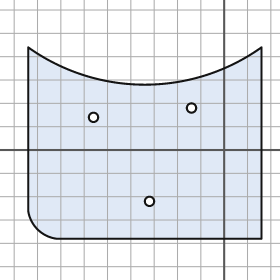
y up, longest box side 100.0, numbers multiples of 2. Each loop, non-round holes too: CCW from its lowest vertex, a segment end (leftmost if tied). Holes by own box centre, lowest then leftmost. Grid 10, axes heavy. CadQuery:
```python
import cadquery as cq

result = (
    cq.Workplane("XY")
    .moveTo(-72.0, -38.0)
    .lineTo(16.0, -38.0)
    .lineTo(16.0, 44.0)
    .threePointArc((-34.0, 28.0), (-84.0, 44.0))
    .lineTo(-84.0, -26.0)
    .threePointArc((-80.0, -34.0), (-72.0, -38.0))
    .close()
    .moveTo(-32.0, -22.0)
    .circle(2.0)
    .moveTo(-56.0, 14.0)
    .circle(2.0)
    .moveTo(-14.0, 18.0)
    .circle(2.0)
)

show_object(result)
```